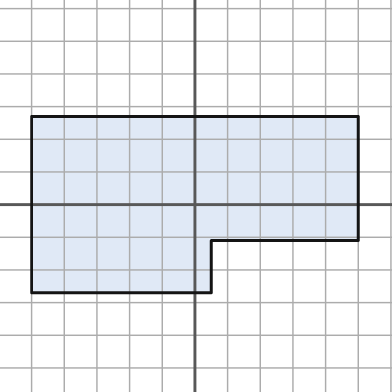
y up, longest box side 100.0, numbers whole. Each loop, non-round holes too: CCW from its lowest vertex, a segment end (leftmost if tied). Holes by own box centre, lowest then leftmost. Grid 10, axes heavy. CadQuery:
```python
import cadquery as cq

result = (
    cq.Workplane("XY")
    .moveTo(-50.0, -27.0)
    .lineTo(5.0, -27.0)
    .lineTo(5.0, -11.0)
    .lineTo(50.0, -11.0)
    .lineTo(50.0, 27.0)
    .lineTo(-50.0, 27.0)
    .close()
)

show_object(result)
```